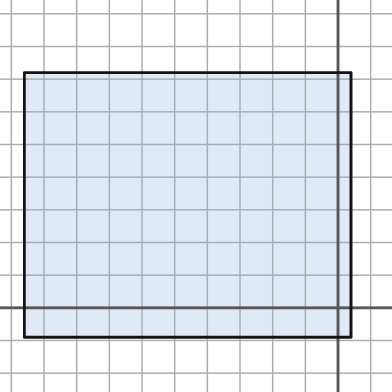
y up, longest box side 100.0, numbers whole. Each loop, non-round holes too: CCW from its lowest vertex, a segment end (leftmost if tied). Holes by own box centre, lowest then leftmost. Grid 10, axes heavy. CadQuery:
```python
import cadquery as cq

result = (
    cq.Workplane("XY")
    .moveTo(-96.0, -9.0)
    .lineTo(4.0, -9.0)
    .lineTo(4.0, 72.0)
    .lineTo(-96.0, 72.0)
    .close()
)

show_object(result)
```